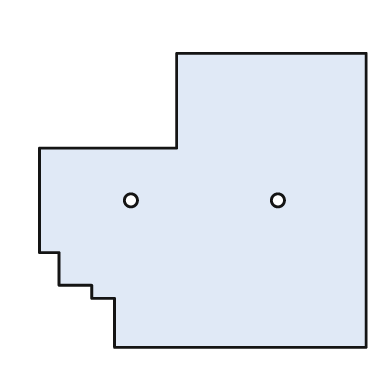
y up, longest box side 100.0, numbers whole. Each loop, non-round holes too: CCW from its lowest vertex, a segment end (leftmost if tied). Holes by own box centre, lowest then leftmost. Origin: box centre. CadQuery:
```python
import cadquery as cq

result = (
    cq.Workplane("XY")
    .moveTo(-27.0, -45.0)
    .lineTo(50.0, -45.0)
    .lineTo(50.0, 45.0)
    .lineTo(-8.0, 45.0)
    .lineTo(-8.0, 16.0)
    .lineTo(-50.0, 16.0)
    .lineTo(-50.0, -16.0)
    .lineTo(-44.0, -16.0)
    .lineTo(-44.0, -26.0)
    .lineTo(-34.0, -26.0)
    .lineTo(-34.0, -30.0)
    .lineTo(-27.0, -30.0)
    .close()
    .moveTo(-22.0, 0.0)
    .circle(2.0)
    .moveTo(23.0, 0.0)
    .circle(2.0)
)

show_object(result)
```